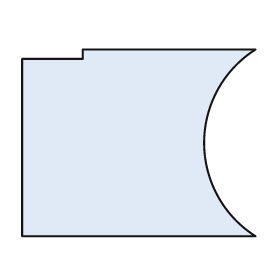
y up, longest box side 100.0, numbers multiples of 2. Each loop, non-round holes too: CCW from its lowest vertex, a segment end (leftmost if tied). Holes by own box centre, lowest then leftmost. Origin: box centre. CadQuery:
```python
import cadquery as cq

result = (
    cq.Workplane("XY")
    .moveTo(-50.0, -40.0)
    .lineTo(50.0, -40.0)
    .threePointArc((28.0, 0.0), (50.0, 40.0))
    .lineTo(-24.0, 40.0)
    .lineTo(-24.0, 36.0)
    .lineTo(-50.0, 36.0)
    .close()
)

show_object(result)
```